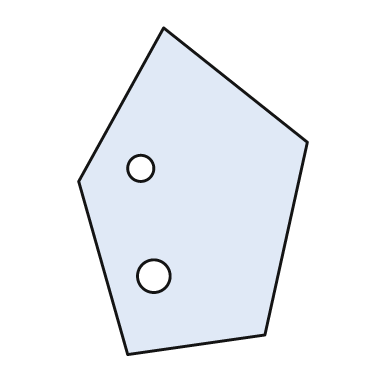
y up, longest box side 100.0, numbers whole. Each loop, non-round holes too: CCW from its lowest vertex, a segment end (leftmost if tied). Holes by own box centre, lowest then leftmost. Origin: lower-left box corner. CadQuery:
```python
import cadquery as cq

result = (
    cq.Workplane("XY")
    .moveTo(15.0, 0.0)
    .lineTo(57.0, 6.0)
    .lineTo(70.0, 65.0)
    .lineTo(26.0, 100.0)
    .lineTo(0.0, 53.0)
    .close()
    .moveTo(23.0, 24.0)
    .circle(5.0)
    .moveTo(19.0, 57.0)
    .circle(4.0)
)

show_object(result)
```